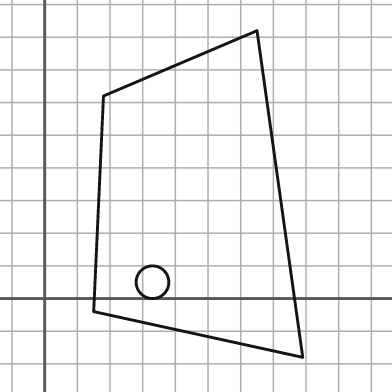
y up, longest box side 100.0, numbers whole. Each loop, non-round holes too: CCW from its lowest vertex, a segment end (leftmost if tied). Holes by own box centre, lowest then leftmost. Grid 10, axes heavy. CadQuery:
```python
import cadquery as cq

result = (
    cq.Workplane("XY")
    .moveTo(79.0, -18.0)
    .lineTo(65.0, 82.0)
    .lineTo(18.0, 62.0)
    .lineTo(15.0, -4.0)
    .close()
    .moveTo(33.0, 5.0)
    .circle(5.0)
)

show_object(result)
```